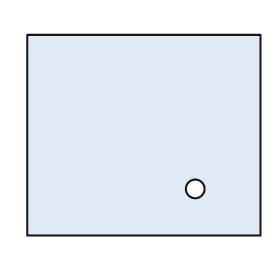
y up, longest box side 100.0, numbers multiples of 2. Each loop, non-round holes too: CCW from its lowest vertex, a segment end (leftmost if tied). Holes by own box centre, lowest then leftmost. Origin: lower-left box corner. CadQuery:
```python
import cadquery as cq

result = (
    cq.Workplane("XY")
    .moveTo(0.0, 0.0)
    .lineTo(100.0, 0.0)
    .lineTo(100.0, 86.0)
    .lineTo(0.0, 86.0)
    .close()
    .moveTo(72.0, 20.0)
    .circle(4.0)
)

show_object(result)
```